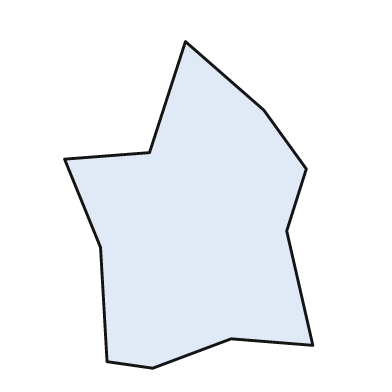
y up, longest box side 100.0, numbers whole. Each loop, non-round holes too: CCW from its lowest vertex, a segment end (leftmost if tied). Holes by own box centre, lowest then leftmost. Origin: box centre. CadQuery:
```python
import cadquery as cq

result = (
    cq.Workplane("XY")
    .moveTo(-11.0, -50.0)
    .lineTo(13.0, -41.0)
    .lineTo(38.0, -43.0)
    .lineTo(30.0, -8.0)
    .lineTo(36.0, 11.0)
    .lineTo(23.0, 29.0)
    .lineTo(-1.0, 50.0)
    .lineTo(-12.0, 16.0)
    .lineTo(-38.0, 14.0)
    .lineTo(-27.0, -13.0)
    .lineTo(-25.0, -48.0)
    .close()
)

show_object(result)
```